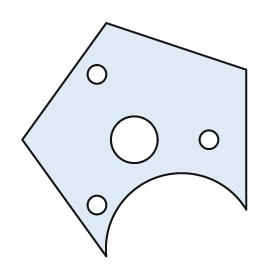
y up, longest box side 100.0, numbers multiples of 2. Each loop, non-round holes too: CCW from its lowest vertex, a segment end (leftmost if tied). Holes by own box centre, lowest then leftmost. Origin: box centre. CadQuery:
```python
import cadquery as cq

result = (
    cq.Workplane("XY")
    .moveTo(-12.0, -50.0)
    .threePointArc((10.0, -16.0), (48.0, -30.0))
    .lineTo(48.0, 30.0)
    .lineTo(-12.0, 50.0)
    .lineTo(-48.0, 0.0)
    .close()
    .moveTo(-16.0, -28.0)
    .circle(4.0)
    .moveTo(0.0, 0.0)
    .circle(10.0)
    .moveTo(32.0, 0.0)
    .circle(4.0)
    .moveTo(-16.0, 28.0)
    .circle(4.0)
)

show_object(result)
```